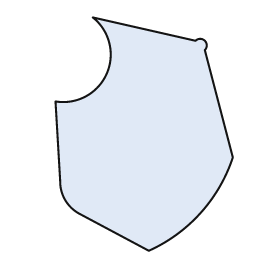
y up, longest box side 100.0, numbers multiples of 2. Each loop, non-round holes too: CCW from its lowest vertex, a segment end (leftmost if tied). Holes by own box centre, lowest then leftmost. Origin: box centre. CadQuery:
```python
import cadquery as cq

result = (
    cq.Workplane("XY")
    .moveTo(2.0, -50.0)
    .threePointArc((24.0, -34.0), (38.0, -10.0))
    .lineTo(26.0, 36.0)
    .threePointArc((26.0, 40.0), (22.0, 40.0))
    .lineTo(-22.0, 50.0)
    .threePointArc((-16.0, 26.0), (-38.0, 14.0))
    .lineTo(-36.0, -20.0)
    .threePointArc((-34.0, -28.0), (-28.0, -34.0))
    .close()
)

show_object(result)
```